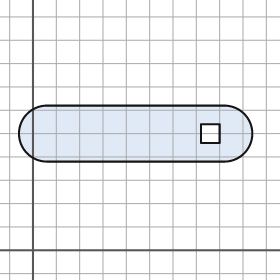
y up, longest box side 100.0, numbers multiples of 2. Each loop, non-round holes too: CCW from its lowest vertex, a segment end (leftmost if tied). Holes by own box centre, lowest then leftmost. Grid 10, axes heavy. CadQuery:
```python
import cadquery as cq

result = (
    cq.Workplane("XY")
    .moveTo(6.0, 38.0)
    .lineTo(82.0, 38.0)
    .threePointArc((94.0, 50.0), (82.0, 62.0))
    .lineTo(6.0, 62.0)
    .threePointArc((-6.0, 50.0), (6.0, 38.0))
    .close()
    .moveTo(72.0, 46.0)
    .lineTo(80.0, 46.0)
    .lineTo(80.0, 54.0)
    .lineTo(72.0, 54.0)
    .close()
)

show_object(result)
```